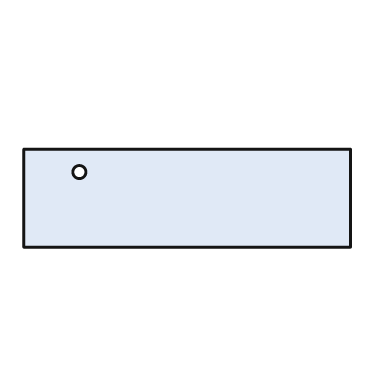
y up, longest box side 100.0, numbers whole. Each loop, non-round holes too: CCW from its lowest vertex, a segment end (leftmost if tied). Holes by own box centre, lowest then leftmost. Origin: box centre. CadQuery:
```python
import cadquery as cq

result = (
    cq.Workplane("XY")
    .moveTo(-50.0, -15.0)
    .lineTo(50.0, -15.0)
    .lineTo(50.0, 15.0)
    .lineTo(-50.0, 15.0)
    .close()
    .moveTo(-33.0, 8.0)
    .circle(2.0)
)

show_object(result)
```